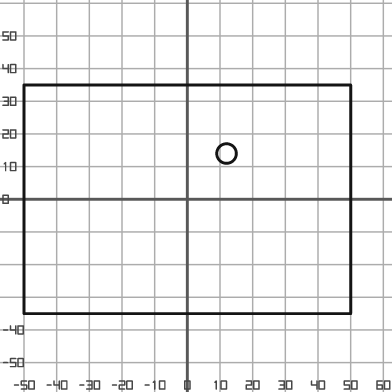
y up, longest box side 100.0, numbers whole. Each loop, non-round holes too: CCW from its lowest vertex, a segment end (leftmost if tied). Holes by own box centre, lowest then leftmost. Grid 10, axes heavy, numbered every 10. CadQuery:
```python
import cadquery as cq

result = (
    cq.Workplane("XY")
    .moveTo(-50.0, -35.0)
    .lineTo(50.0, -35.0)
    .lineTo(50.0, 35.0)
    .lineTo(-50.0, 35.0)
    .close()
    .moveTo(12.0, 14.0)
    .circle(3.0)
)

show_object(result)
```